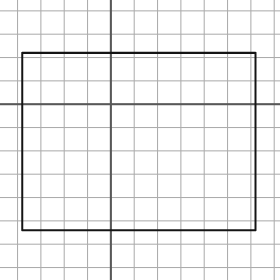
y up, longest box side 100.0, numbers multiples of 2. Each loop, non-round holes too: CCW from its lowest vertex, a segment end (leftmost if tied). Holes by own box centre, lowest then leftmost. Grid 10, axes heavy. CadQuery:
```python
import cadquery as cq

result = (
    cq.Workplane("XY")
    .moveTo(-38.0, -54.0)
    .lineTo(62.0, -54.0)
    .lineTo(62.0, 22.0)
    .lineTo(-38.0, 22.0)
    .close()
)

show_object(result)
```